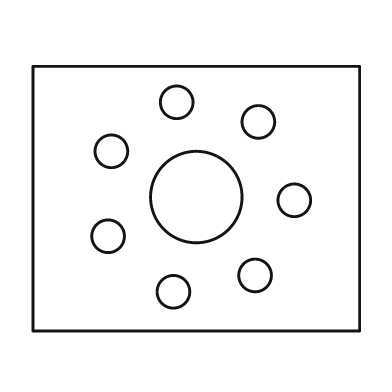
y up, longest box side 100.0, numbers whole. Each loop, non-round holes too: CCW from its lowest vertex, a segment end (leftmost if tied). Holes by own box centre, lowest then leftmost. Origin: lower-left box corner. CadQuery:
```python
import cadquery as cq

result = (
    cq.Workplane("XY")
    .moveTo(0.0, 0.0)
    .lineTo(100.0, 0.0)
    .lineTo(100.0, 81.0)
    .lineTo(0.0, 81.0)
    .close()
    .moveTo(43.0, 12.0)
    .circle(5.0)
    .moveTo(68.0, 17.0)
    .circle(5.0)
    .moveTo(23.0, 29.0)
    .circle(5.0)
    .moveTo(80.0, 40.0)
    .circle(5.0)
    .moveTo(50.0, 41.0)
    .circle(14.0)
    .moveTo(24.0, 55.0)
    .circle(5.0)
    .moveTo(69.0, 64.0)
    .circle(5.0)
    .moveTo(44.0, 70.0)
    .circle(5.0)
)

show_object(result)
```